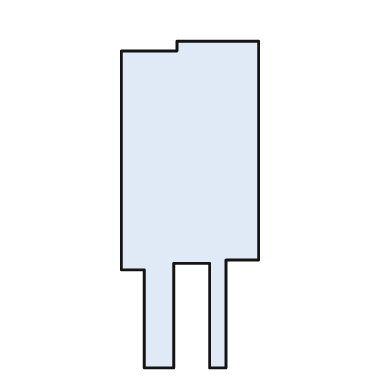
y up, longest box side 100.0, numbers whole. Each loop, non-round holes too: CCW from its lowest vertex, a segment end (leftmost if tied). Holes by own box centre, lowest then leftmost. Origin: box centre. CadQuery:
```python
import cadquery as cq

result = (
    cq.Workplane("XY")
    .moveTo(-14.0, -50.0)
    .lineTo(-5.0, -50.0)
    .lineTo(-5.0, -18.0)
    .lineTo(6.0, -18.0)
    .lineTo(6.0, -50.0)
    .lineTo(11.0, -50.0)
    .lineTo(11.0, -17.0)
    .lineTo(21.0, -17.0)
    .lineTo(21.0, 50.0)
    .lineTo(-4.0, 50.0)
    .lineTo(-4.0, 47.0)
    .lineTo(-21.0, 47.0)
    .lineTo(-21.0, -20.0)
    .lineTo(-14.0, -20.0)
    .close()
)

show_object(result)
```